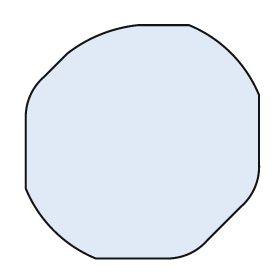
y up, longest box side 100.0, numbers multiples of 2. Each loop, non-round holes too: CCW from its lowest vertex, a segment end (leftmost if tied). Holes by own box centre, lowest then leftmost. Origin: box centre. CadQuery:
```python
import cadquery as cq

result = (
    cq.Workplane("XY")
    .moveTo(-20.0, -50.0)
    .lineTo(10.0, -50.0)
    .threePointArc((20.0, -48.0), (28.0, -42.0))
    .lineTo(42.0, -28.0)
    .threePointArc((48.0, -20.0), (50.0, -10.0))
    .lineTo(50.0, 20.0)
    .threePointArc((38.0, 38.0), (20.0, 50.0))
    .lineTo(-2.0, 50.0)
    .threePointArc((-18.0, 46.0), (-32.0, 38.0))
    .lineTo(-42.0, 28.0)
    .threePointArc((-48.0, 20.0), (-50.0, 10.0))
    .lineTo(-50.0, -20.0)
    .threePointArc((-38.0, -38.0), (-20.0, -50.0))
    .close()
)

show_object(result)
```